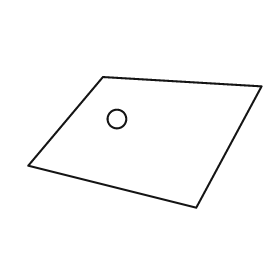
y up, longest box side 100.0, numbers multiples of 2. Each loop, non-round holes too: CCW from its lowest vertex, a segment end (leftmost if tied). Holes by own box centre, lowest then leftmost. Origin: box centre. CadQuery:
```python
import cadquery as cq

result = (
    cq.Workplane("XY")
    .moveTo(22.0, -28.0)
    .lineTo(50.0, 24.0)
    .lineTo(-18.0, 28.0)
    .lineTo(-50.0, -10.0)
    .close()
    .moveTo(-12.0, 10.0)
    .circle(4.0)
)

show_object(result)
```